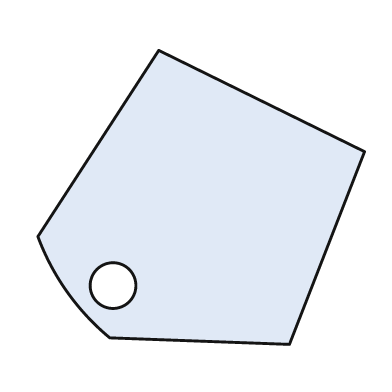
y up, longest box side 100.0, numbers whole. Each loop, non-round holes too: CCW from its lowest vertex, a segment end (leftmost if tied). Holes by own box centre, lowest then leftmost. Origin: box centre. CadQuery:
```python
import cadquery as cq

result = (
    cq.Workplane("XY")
    .moveTo(27.0, -45.0)
    .lineTo(50.0, 14.0)
    .lineTo(-13.0, 45.0)
    .lineTo(-50.0, -12.0)
    .threePointArc((-41.0, -29.0), (-28.0, -43.0))
    .close()
    .moveTo(-27.0, -27.0)
    .circle(7.0)
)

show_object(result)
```